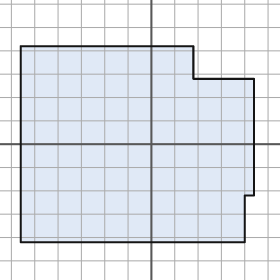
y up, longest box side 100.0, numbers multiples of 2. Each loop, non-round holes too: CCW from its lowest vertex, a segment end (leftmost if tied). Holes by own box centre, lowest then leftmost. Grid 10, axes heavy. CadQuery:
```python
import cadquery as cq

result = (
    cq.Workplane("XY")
    .moveTo(-56.0, -42.0)
    .lineTo(40.0, -42.0)
    .lineTo(40.0, -22.0)
    .lineTo(44.0, -22.0)
    .lineTo(44.0, 28.0)
    .lineTo(18.0, 28.0)
    .lineTo(18.0, 42.0)
    .lineTo(-56.0, 42.0)
    .close()
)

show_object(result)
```